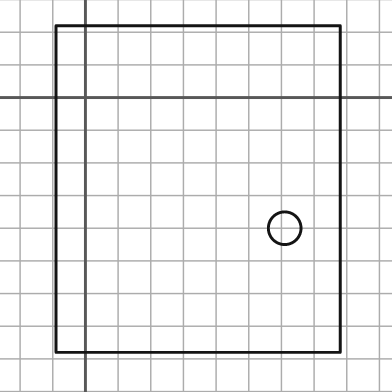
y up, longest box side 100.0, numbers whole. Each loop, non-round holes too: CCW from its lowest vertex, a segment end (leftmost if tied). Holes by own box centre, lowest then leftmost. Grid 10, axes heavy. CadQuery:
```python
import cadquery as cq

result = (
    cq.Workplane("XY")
    .moveTo(-9.0, -78.0)
    .lineTo(78.0, -78.0)
    .lineTo(78.0, 22.0)
    .lineTo(-9.0, 22.0)
    .close()
    .moveTo(61.0, -40.0)
    .circle(5.0)
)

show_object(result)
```